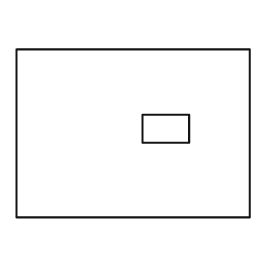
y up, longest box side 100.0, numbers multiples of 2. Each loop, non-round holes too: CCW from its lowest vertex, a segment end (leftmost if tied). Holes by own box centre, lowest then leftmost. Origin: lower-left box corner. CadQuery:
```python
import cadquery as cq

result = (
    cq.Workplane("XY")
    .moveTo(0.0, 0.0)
    .lineTo(100.0, 0.0)
    .lineTo(100.0, 72.0)
    .lineTo(0.0, 72.0)
    .close()
    .moveTo(54.0, 32.0)
    .lineTo(74.0, 32.0)
    .lineTo(74.0, 44.0)
    .lineTo(54.0, 44.0)
    .close()
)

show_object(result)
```